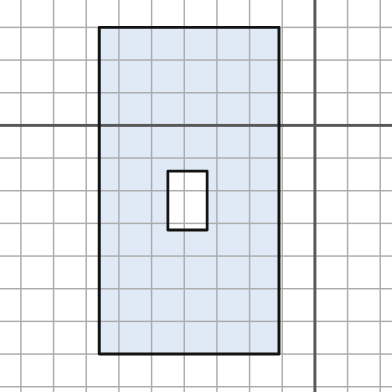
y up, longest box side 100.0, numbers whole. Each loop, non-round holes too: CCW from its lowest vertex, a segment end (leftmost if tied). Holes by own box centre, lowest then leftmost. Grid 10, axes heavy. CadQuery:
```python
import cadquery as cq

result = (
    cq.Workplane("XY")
    .moveTo(-66.0, -70.0)
    .lineTo(-11.0, -70.0)
    .lineTo(-11.0, 30.0)
    .lineTo(-66.0, 30.0)
    .close()
    .moveTo(-45.0, -32.0)
    .lineTo(-33.0, -32.0)
    .lineTo(-33.0, -14.0)
    .lineTo(-45.0, -14.0)
    .close()
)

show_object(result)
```